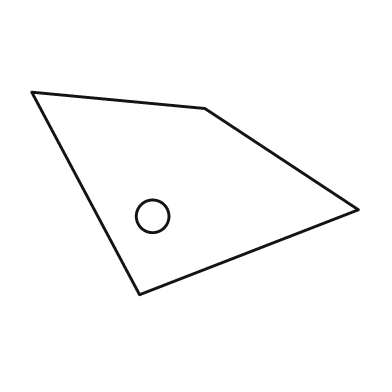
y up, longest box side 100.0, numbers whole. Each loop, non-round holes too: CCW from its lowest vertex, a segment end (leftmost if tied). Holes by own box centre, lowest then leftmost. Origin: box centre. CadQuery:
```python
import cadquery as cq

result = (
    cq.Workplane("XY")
    .moveTo(-17.0, -31.0)
    .lineTo(50.0, -5.0)
    .lineTo(3.0, 26.0)
    .lineTo(-50.0, 31.0)
    .close()
    .moveTo(-13.0, -7.0)
    .circle(5.0)
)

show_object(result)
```